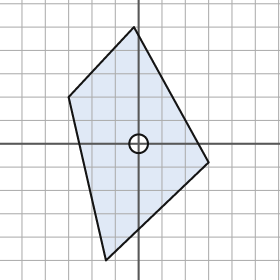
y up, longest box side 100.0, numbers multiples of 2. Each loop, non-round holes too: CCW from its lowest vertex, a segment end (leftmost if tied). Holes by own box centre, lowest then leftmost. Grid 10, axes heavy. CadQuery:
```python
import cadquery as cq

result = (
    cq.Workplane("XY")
    .moveTo(-14.0, -50.0)
    .lineTo(30.0, -8.0)
    .lineTo(-2.0, 50.0)
    .lineTo(-30.0, 20.0)
    .close()
    .moveTo(0.0, 0.0)
    .circle(4.0)
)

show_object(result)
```